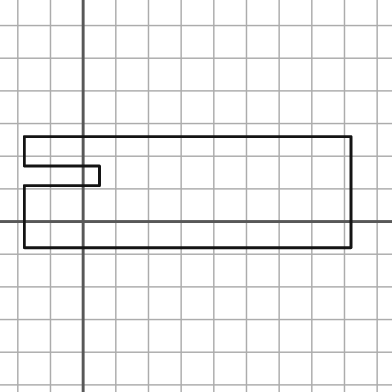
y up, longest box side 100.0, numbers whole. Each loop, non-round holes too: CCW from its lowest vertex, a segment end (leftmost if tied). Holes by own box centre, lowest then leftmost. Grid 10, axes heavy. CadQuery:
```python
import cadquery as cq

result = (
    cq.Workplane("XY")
    .moveTo(-18.0, -8.0)
    .lineTo(82.0, -8.0)
    .lineTo(82.0, 26.0)
    .lineTo(-18.0, 26.0)
    .lineTo(-18.0, 17.0)
    .lineTo(5.0, 17.0)
    .lineTo(5.0, 11.0)
    .lineTo(-18.0, 11.0)
    .close()
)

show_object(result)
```